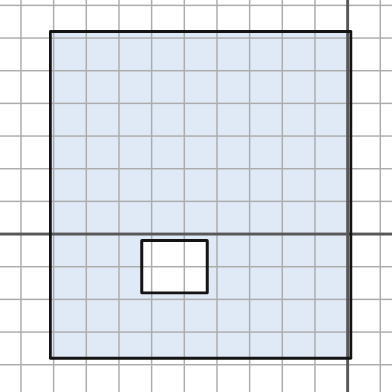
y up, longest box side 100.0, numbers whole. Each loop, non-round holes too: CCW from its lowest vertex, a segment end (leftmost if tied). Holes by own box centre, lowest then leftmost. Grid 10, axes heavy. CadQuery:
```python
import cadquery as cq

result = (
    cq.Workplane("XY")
    .moveTo(-91.0, -38.0)
    .lineTo(1.0, -38.0)
    .lineTo(1.0, 62.0)
    .lineTo(-91.0, 62.0)
    .close()
    .moveTo(-63.0, -18.0)
    .lineTo(-43.0, -18.0)
    .lineTo(-43.0, -2.0)
    .lineTo(-63.0, -2.0)
    .close()
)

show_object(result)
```